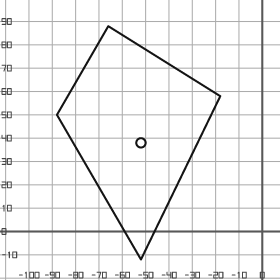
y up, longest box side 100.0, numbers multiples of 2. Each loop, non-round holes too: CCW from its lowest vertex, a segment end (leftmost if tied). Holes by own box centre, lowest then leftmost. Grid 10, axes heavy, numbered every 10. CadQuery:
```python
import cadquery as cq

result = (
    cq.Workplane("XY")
    .moveTo(-52.0, -12.0)
    .lineTo(-18.0, 58.0)
    .lineTo(-66.0, 88.0)
    .lineTo(-88.0, 50.0)
    .close()
    .moveTo(-52.0, 38.0)
    .circle(2.0)
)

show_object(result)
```